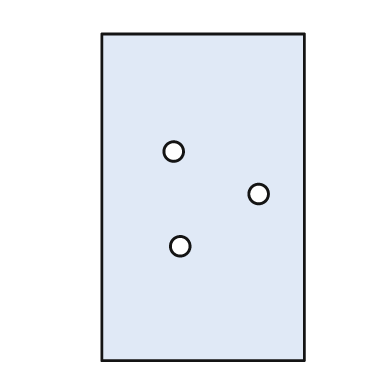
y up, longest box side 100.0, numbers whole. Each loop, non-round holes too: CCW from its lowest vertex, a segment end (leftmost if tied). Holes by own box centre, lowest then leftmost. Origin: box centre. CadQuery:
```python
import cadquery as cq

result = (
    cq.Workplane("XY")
    .moveTo(-31.0, -50.0)
    .lineTo(31.0, -50.0)
    .lineTo(31.0, 50.0)
    .lineTo(-31.0, 50.0)
    .close()
    .moveTo(-7.0, -15.0)
    .circle(3.0)
    .moveTo(17.0, 1.0)
    .circle(3.0)
    .moveTo(-9.0, 14.0)
    .circle(3.0)
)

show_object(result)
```